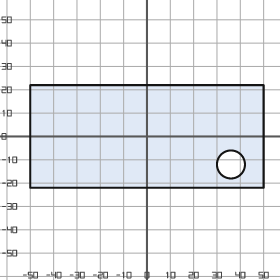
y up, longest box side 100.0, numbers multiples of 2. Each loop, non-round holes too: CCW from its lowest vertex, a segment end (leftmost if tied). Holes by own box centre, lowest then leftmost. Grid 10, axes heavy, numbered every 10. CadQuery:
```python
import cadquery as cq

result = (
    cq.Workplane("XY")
    .moveTo(-50.0, -22.0)
    .lineTo(50.0, -22.0)
    .lineTo(50.0, 22.0)
    .lineTo(-50.0, 22.0)
    .close()
    .moveTo(36.0, -12.0)
    .circle(6.0)
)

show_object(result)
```